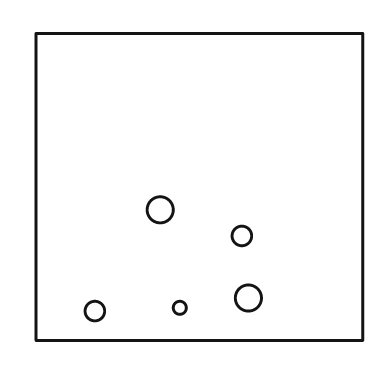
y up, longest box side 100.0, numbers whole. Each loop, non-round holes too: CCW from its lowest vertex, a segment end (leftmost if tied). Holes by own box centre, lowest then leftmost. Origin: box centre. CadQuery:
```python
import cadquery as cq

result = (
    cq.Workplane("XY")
    .moveTo(-50.0, -47.0)
    .lineTo(50.0, -47.0)
    .lineTo(50.0, 47.0)
    .lineTo(-50.0, 47.0)
    .close()
    .moveTo(-32.0, -38.0)
    .circle(3.0)
    .moveTo(-6.0, -37.0)
    .circle(2.0)
    .moveTo(15.0, -34.0)
    .circle(4.0)
    .moveTo(13.0, -15.0)
    .circle(3.0)
    .moveTo(-12.0, -7.0)
    .circle(4.0)
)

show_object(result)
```